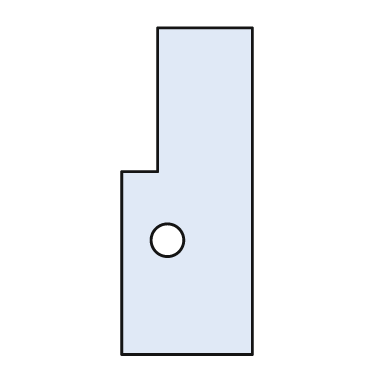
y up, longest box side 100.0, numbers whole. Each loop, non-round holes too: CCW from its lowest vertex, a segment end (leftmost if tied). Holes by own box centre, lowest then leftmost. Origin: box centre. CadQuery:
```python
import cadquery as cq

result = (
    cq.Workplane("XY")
    .moveTo(-20.0, -50.0)
    .lineTo(20.0, -50.0)
    .lineTo(20.0, 50.0)
    .lineTo(-9.0, 50.0)
    .lineTo(-9.0, 6.0)
    .lineTo(-20.0, 6.0)
    .close()
    .moveTo(-6.0, -15.0)
    .circle(5.0)
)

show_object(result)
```